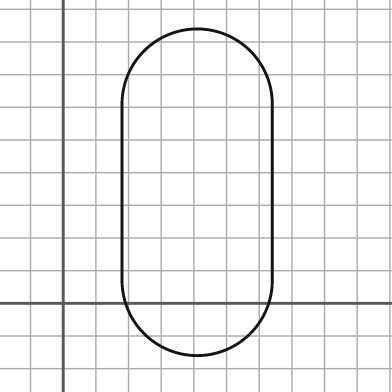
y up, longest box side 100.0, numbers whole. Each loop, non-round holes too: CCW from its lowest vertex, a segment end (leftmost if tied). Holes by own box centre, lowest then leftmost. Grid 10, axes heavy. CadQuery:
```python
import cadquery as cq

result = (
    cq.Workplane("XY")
    .moveTo(18.0, 7.0)
    .threePointArc((41.0, -16.0), (64.0, 7.0))
    .lineTo(64.0, 61.0)
    .threePointArc((41.0, 84.0), (18.0, 61.0))
    .close()
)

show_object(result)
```